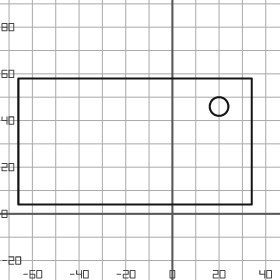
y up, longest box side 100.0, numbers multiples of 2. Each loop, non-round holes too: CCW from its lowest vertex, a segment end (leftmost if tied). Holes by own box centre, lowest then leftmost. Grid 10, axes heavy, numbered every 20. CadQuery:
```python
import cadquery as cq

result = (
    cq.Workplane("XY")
    .moveTo(-66.0, 4.0)
    .lineTo(34.0, 4.0)
    .lineTo(34.0, 58.0)
    .lineTo(-66.0, 58.0)
    .close()
    .moveTo(20.0, 46.0)
    .circle(4.0)
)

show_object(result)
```